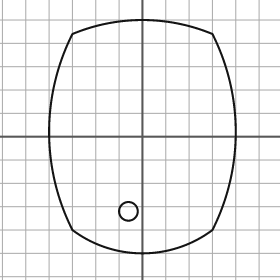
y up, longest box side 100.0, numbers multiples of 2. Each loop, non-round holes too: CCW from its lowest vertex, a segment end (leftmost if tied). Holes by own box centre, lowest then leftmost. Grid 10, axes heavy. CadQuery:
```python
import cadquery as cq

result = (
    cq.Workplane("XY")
    .moveTo(-30.0, -40.0)
    .threePointArc((0.0, -50.0), (30.0, -40.0))
    .threePointArc((40.0, 2.0), (30.0, 44.0))
    .threePointArc((0.0, 50.0), (-30.0, 44.0))
    .threePointArc((-40.0, 2.0), (-30.0, -40.0))
    .close()
    .moveTo(-6.0, -32.0)
    .circle(4.0)
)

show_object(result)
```